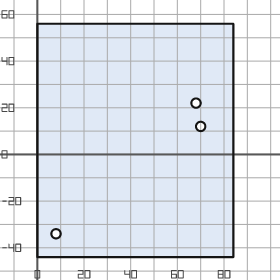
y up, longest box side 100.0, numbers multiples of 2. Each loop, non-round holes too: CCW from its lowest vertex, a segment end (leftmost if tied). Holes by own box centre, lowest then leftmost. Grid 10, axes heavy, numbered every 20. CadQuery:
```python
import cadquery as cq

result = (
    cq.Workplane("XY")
    .moveTo(0.0, -44.0)
    .lineTo(84.0, -44.0)
    .lineTo(84.0, 56.0)
    .lineTo(0.0, 56.0)
    .close()
    .moveTo(8.0, -34.0)
    .circle(2.0)
    .moveTo(70.0, 12.0)
    .circle(2.0)
    .moveTo(68.0, 22.0)
    .circle(2.0)
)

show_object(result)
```